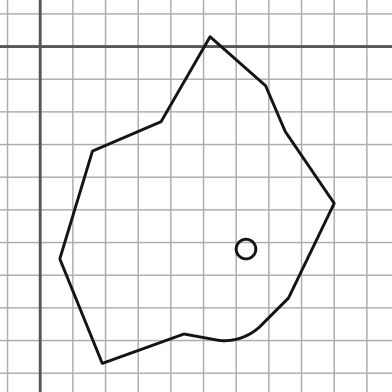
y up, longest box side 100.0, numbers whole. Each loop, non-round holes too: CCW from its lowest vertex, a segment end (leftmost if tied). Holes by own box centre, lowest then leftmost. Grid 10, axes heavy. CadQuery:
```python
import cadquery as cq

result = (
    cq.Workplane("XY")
    .moveTo(19.0, -97.0)
    .lineTo(44.0, -88.0)
    .lineTo(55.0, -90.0)
    .threePointArc((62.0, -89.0), (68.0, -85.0))
    .lineTo(76.0, -77.0)
    .lineTo(90.0, -48.0)
    .lineTo(75.0, -26.0)
    .lineTo(69.0, -12.0)
    .lineTo(52.0, 3.0)
    .lineTo(37.0, -23.0)
    .lineTo(16.0, -32.0)
    .lineTo(6.0, -65.0)
    .close()
    .moveTo(63.0, -62.0)
    .circle(3.0)
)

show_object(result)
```